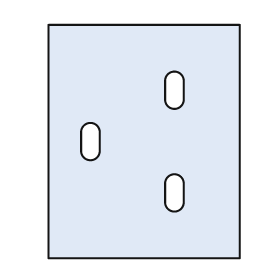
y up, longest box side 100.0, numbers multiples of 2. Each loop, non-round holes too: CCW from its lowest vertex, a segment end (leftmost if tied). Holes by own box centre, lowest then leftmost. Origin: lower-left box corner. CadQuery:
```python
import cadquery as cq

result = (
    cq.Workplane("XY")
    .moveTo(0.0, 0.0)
    .lineTo(82.0, 0.0)
    .lineTo(82.0, 100.0)
    .lineTo(0.0, 100.0)
    .close()
    .moveTo(50.0, 24.0)
    .threePointArc((54.0, 20.0), (58.0, 24.0))
    .lineTo(58.0, 32.0)
    .threePointArc((54.0, 36.0), (50.0, 32.0))
    .close()
    .moveTo(14.0, 46.0)
    .threePointArc((18.0, 42.0), (22.0, 46.0))
    .lineTo(22.0, 54.0)
    .threePointArc((18.0, 58.0), (14.0, 54.0))
    .close()
    .moveTo(50.0, 68.0)
    .threePointArc((54.0, 64.0), (58.0, 68.0))
    .lineTo(58.0, 76.0)
    .threePointArc((54.0, 80.0), (50.0, 76.0))
    .close()
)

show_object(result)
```